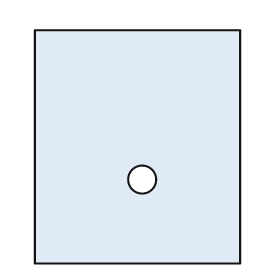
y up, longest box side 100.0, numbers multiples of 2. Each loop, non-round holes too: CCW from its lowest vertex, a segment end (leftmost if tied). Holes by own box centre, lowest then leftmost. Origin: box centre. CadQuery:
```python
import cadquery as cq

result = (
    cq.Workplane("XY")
    .moveTo(-44.0, -50.0)
    .lineTo(44.0, -50.0)
    .lineTo(44.0, 50.0)
    .lineTo(-44.0, 50.0)
    .close()
    .moveTo(2.0, -14.0)
    .circle(6.0)
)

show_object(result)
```